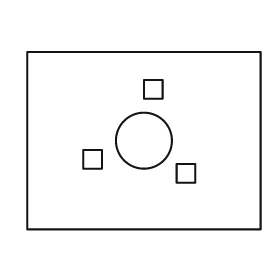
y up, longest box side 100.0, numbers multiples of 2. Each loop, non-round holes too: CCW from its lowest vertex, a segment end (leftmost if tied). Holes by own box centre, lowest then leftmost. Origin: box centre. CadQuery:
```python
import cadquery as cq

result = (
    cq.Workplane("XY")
    .moveTo(-50.0, -38.0)
    .lineTo(50.0, -38.0)
    .lineTo(50.0, 38.0)
    .lineTo(-50.0, 38.0)
    .close()
    .moveTo(14.0, -18.0)
    .lineTo(22.0, -18.0)
    .lineTo(22.0, -10.0)
    .lineTo(14.0, -10.0)
    .close()
    .moveTo(-26.0, -12.0)
    .lineTo(-18.0, -12.0)
    .lineTo(-18.0, -4.0)
    .lineTo(-26.0, -4.0)
    .close()
    .moveTo(0.0, 0.0)
    .circle(12.0)
    .moveTo(0.0, 18.0)
    .lineTo(8.0, 18.0)
    .lineTo(8.0, 26.0)
    .lineTo(0.0, 26.0)
    .close()
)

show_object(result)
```